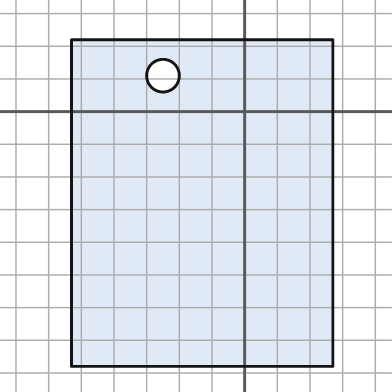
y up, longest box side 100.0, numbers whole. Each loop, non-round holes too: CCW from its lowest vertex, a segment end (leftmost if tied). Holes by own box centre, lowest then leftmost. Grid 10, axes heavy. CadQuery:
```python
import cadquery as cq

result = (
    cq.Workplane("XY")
    .moveTo(-53.0, -78.0)
    .lineTo(27.0, -78.0)
    .lineTo(27.0, 22.0)
    .lineTo(-53.0, 22.0)
    .close()
    .moveTo(-25.0, 11.0)
    .circle(5.0)
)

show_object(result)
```